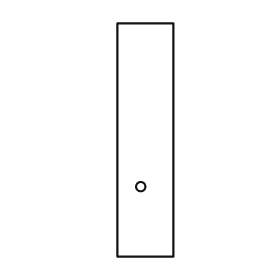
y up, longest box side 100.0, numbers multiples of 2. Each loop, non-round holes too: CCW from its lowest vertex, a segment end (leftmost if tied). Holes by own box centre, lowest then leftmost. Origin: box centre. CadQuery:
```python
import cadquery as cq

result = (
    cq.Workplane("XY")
    .moveTo(-12.0, -50.0)
    .lineTo(12.0, -50.0)
    .lineTo(12.0, 50.0)
    .lineTo(-12.0, 50.0)
    .close()
    .moveTo(-2.0, -20.0)
    .circle(2.0)
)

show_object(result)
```